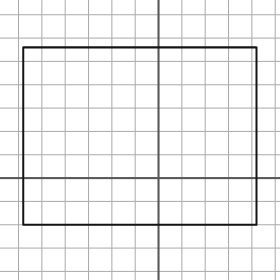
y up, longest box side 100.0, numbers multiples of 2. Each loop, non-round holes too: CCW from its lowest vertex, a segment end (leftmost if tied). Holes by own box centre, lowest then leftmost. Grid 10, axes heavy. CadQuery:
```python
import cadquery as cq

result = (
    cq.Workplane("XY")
    .moveTo(-58.0, -20.0)
    .lineTo(42.0, -20.0)
    .lineTo(42.0, 56.0)
    .lineTo(-58.0, 56.0)
    .close()
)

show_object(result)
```